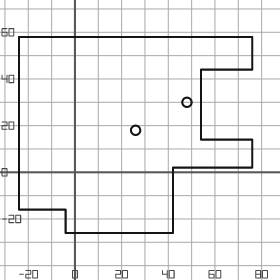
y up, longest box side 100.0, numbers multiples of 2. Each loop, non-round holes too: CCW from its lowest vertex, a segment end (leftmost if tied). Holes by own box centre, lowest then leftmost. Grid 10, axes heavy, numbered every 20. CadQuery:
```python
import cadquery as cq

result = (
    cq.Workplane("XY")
    .moveTo(-4.0, -26.0)
    .lineTo(42.0, -26.0)
    .lineTo(42.0, 2.0)
    .lineTo(76.0, 2.0)
    .lineTo(76.0, 14.0)
    .lineTo(54.0, 14.0)
    .lineTo(54.0, 44.0)
    .lineTo(76.0, 44.0)
    .lineTo(76.0, 58.0)
    .lineTo(-24.0, 58.0)
    .lineTo(-24.0, -16.0)
    .lineTo(-4.0, -16.0)
    .close()
    .moveTo(26.0, 18.0)
    .circle(2.0)
    .moveTo(48.0, 30.0)
    .circle(2.0)
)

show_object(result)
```